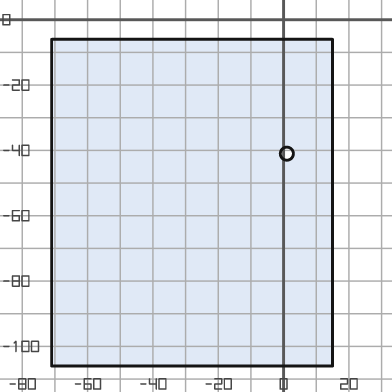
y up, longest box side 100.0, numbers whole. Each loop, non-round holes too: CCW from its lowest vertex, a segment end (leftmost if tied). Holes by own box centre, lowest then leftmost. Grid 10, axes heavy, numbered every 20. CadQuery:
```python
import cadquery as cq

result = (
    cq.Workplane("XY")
    .moveTo(-71.0, -106.0)
    .lineTo(15.0, -106.0)
    .lineTo(15.0, -6.0)
    .lineTo(-71.0, -6.0)
    .close()
    .moveTo(1.0, -41.0)
    .circle(2.0)
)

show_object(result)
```